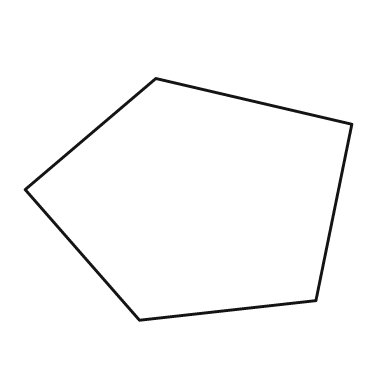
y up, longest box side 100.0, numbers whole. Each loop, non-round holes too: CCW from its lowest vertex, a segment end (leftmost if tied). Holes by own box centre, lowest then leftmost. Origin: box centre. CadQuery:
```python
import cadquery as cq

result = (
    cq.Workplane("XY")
    .moveTo(-15.0, -37.0)
    .lineTo(39.0, -31.0)
    .lineTo(50.0, 23.0)
    .lineTo(-10.0, 37.0)
    .lineTo(-50.0, 3.0)
    .close()
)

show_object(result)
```